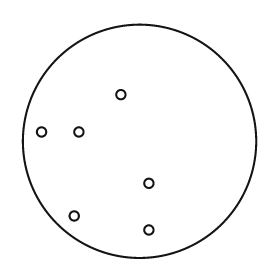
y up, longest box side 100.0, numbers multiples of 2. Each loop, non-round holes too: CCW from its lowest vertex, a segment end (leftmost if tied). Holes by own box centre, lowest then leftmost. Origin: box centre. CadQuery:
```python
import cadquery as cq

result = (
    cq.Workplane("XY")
    .moveTo(0.0, 0.0)
    .circle(50.0)
    .moveTo(4.0, -38.0)
    .circle(2.0)
    .moveTo(-28.0, -32.0)
    .circle(2.0)
    .moveTo(4.0, -18.0)
    .circle(2.0)
    .moveTo(-42.0, 4.0)
    .circle(2.0)
    .moveTo(-26.0, 4.0)
    .circle(2.0)
    .moveTo(-8.0, 20.0)
    .circle(2.0)
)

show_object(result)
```